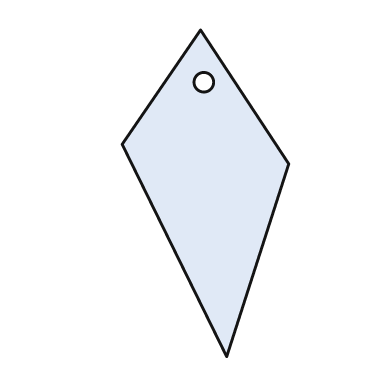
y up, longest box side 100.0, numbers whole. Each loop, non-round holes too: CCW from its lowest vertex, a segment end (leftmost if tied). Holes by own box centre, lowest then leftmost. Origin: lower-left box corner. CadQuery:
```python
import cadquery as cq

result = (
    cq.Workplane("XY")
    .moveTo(32.0, 0.0)
    .lineTo(51.0, 59.0)
    .lineTo(24.0, 100.0)
    .lineTo(0.0, 65.0)
    .close()
    .moveTo(25.0, 84.0)
    .circle(3.0)
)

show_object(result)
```